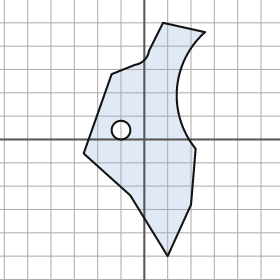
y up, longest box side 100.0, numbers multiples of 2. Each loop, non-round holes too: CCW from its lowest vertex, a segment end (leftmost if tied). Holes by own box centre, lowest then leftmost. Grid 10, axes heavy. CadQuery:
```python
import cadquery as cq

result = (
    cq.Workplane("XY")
    .moveTo(10.0, -50.0)
    .lineTo(20.0, -28.0)
    .lineTo(22.0, -4.0)
    .threePointArc((14.0, 22.0), (26.0, 46.0))
    .lineTo(8.0, 50.0)
    .lineTo(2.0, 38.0)
    .threePointArc((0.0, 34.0), (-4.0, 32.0))
    .lineTo(-14.0, 28.0)
    .lineTo(-26.0, -6.0)
    .lineTo(-6.0, -24.0)
    .close()
    .moveTo(-10.0, 4.0)
    .circle(4.0)
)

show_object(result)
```